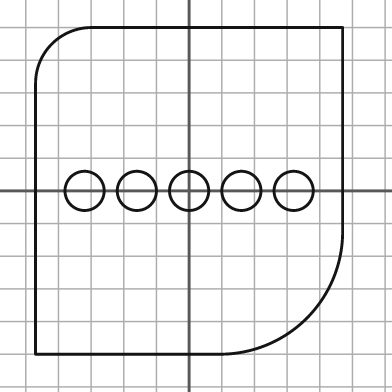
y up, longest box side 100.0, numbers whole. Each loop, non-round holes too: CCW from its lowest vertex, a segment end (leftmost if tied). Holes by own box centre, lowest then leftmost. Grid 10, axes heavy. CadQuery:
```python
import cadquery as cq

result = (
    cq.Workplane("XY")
    .moveTo(-47.0, -50.0)
    .lineTo(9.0, -50.0)
    .threePointArc((36.0, -39.0), (47.0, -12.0))
    .lineTo(47.0, 50.0)
    .lineTo(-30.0, 50.0)
    .threePointArc((-42.0, 45.0), (-47.0, 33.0))
    .close()
    .moveTo(-32.0, 0.0)
    .circle(6.0)
    .moveTo(-16.0, 0.0)
    .circle(6.0)
    .moveTo(0.0, 0.0)
    .circle(6.0)
    .moveTo(16.0, 0.0)
    .circle(6.0)
    .moveTo(32.0, 0.0)
    .circle(6.0)
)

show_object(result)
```